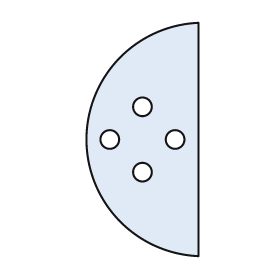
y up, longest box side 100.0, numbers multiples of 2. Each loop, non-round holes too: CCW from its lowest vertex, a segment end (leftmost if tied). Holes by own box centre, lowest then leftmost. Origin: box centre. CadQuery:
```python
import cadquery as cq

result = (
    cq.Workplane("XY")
    .moveTo(24.0, -50.0)
    .lineTo(24.0, 50.0)
    .threePointArc((-24.0, 0.0), (24.0, -50.0))
    .close()
    .moveTo(0.0, -14.0)
    .circle(4.0)
    .moveTo(-14.0, 0.0)
    .circle(4.0)
    .moveTo(14.0, 0.0)
    .circle(4.0)
    .moveTo(0.0, 14.0)
    .circle(4.0)
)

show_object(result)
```